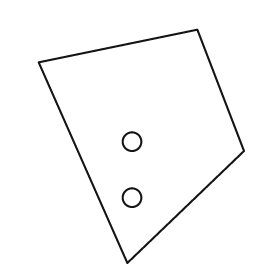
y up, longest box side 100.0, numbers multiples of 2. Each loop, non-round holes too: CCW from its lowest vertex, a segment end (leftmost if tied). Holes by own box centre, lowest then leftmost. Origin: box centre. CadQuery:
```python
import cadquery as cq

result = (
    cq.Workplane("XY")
    .moveTo(-6.0, -50.0)
    .lineTo(44.0, -2.0)
    .lineTo(24.0, 50.0)
    .lineTo(-44.0, 36.0)
    .close()
    .moveTo(-4.0, -22.0)
    .circle(4.0)
    .moveTo(-4.0, 2.0)
    .circle(4.0)
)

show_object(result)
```